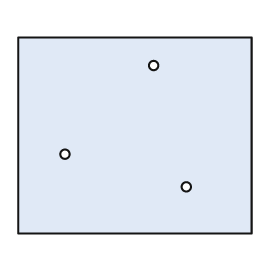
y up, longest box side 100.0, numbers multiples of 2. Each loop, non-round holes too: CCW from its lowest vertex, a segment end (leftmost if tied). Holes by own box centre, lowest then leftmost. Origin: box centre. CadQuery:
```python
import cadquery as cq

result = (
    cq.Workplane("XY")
    .moveTo(-50.0, -42.0)
    .lineTo(50.0, -42.0)
    .lineTo(50.0, 42.0)
    .lineTo(-50.0, 42.0)
    .close()
    .moveTo(22.0, -22.0)
    .circle(2.0)
    .moveTo(-30.0, -8.0)
    .circle(2.0)
    .moveTo(8.0, 30.0)
    .circle(2.0)
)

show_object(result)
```